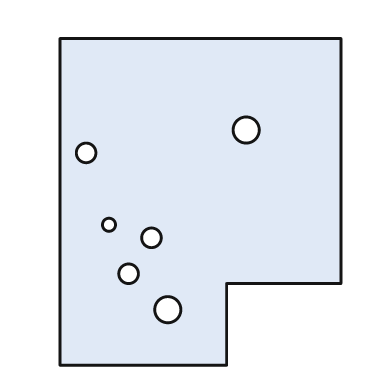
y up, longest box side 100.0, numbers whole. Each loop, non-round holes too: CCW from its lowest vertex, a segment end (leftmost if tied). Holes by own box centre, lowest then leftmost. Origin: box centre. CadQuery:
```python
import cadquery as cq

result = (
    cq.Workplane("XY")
    .moveTo(-43.0, -50.0)
    .lineTo(8.0, -50.0)
    .lineTo(8.0, -25.0)
    .lineTo(43.0, -25.0)
    .lineTo(43.0, 50.0)
    .lineTo(-43.0, 50.0)
    .close()
    .moveTo(-10.0, -33.0)
    .circle(4.0)
    .moveTo(-22.0, -22.0)
    .circle(3.0)
    .moveTo(-15.0, -11.0)
    .circle(3.0)
    .moveTo(-28.0, -7.0)
    .circle(2.0)
    .moveTo(-35.0, 15.0)
    .circle(3.0)
    .moveTo(14.0, 22.0)
    .circle(4.0)
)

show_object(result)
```